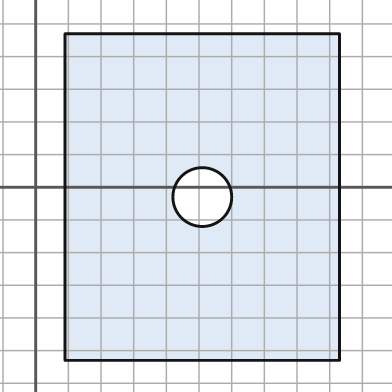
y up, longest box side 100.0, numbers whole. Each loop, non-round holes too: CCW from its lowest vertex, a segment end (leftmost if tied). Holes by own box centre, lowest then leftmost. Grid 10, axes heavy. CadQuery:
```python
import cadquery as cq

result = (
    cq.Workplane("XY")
    .moveTo(9.0, -53.0)
    .lineTo(93.0, -53.0)
    .lineTo(93.0, 47.0)
    .lineTo(9.0, 47.0)
    .close()
    .moveTo(51.0, -3.0)
    .circle(9.0)
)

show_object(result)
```